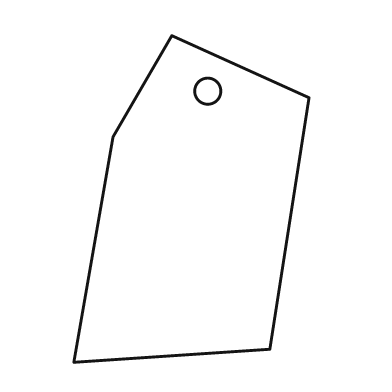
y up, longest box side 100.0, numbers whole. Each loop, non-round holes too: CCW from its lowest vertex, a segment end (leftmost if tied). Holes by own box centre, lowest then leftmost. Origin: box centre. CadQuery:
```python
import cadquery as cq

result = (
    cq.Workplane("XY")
    .moveTo(-36.0, -50.0)
    .lineTo(24.0, -46.0)
    .lineTo(36.0, 31.0)
    .lineTo(-6.0, 50.0)
    .lineTo(-24.0, 19.0)
    .close()
    .moveTo(5.0, 33.0)
    .circle(4.0)
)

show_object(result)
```